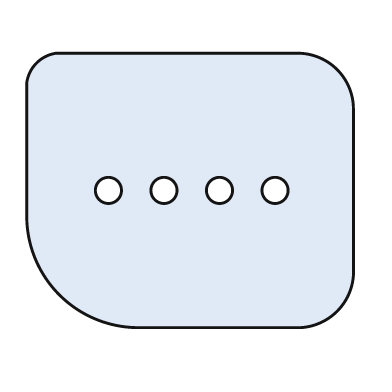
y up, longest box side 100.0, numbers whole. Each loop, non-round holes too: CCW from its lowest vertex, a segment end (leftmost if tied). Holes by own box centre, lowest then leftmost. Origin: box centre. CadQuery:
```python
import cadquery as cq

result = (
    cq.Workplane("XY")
    .moveTo(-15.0, -42.0)
    .lineTo(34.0, -42.0)
    .threePointArc((45.0, -37.0), (50.0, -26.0))
    .lineTo(50.0, 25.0)
    .threePointArc((45.0, 37.0), (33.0, 42.0))
    .lineTo(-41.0, 42.0)
    .threePointArc((-47.0, 39.0), (-50.0, 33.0))
    .lineTo(-50.0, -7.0)
    .threePointArc((-40.0, -32.0), (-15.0, -42.0))
    .close()
    .moveTo(-25.0, 0.0)
    .circle(4.0)
    .moveTo(-8.0, 0.0)
    .circle(4.0)
    .moveTo(9.0, 0.0)
    .circle(4.0)
    .moveTo(26.0, 0.0)
    .circle(4.0)
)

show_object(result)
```